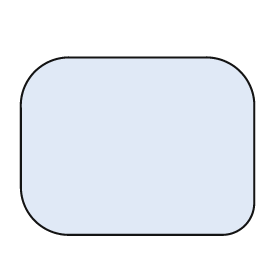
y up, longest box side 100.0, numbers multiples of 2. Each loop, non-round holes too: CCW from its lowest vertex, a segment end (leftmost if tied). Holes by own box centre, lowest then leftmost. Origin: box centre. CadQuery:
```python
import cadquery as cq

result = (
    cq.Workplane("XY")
    .moveTo(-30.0, -38.0)
    .lineTo(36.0, -38.0)
    .threePointArc((46.0, -34.0), (50.0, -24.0))
    .lineTo(50.0, 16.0)
    .threePointArc((44.0, 32.0), (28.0, 38.0))
    .lineTo(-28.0, 38.0)
    .threePointArc((-44.0, 32.0), (-50.0, 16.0))
    .lineTo(-50.0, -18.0)
    .threePointArc((-44.0, -32.0), (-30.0, -38.0))
    .close()
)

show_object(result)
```